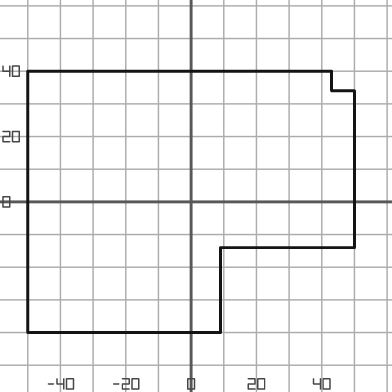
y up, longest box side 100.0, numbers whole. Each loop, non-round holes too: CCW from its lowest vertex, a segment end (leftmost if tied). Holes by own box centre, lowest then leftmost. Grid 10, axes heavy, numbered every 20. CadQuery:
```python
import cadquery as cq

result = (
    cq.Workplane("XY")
    .moveTo(-50.0, -40.0)
    .lineTo(9.0, -40.0)
    .lineTo(9.0, -14.0)
    .lineTo(50.0, -14.0)
    .lineTo(50.0, 34.0)
    .lineTo(43.0, 34.0)
    .lineTo(43.0, 40.0)
    .lineTo(-50.0, 40.0)
    .close()
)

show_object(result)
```